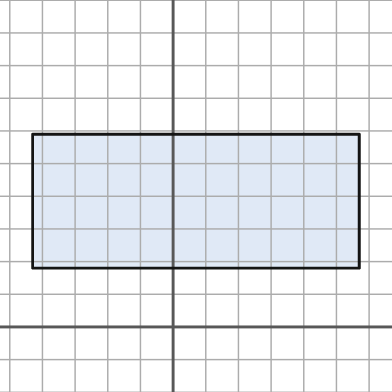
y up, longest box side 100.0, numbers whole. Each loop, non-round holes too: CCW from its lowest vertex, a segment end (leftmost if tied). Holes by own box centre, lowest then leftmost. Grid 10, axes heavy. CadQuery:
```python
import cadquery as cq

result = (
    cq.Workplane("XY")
    .moveTo(-43.0, 18.0)
    .lineTo(57.0, 18.0)
    .lineTo(57.0, 59.0)
    .lineTo(-43.0, 59.0)
    .close()
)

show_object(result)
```